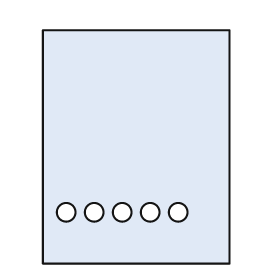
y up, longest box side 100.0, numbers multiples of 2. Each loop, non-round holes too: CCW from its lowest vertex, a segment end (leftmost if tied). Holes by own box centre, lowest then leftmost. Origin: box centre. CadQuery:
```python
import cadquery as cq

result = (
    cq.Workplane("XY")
    .moveTo(-40.0, -50.0)
    .lineTo(40.0, -50.0)
    .lineTo(40.0, 50.0)
    .lineTo(-40.0, 50.0)
    .close()
    .moveTo(-30.0, -28.0)
    .circle(4.0)
    .moveTo(-18.0, -28.0)
    .circle(4.0)
    .moveTo(-6.0, -28.0)
    .circle(4.0)
    .moveTo(6.0, -28.0)
    .circle(4.0)
    .moveTo(18.0, -28.0)
    .circle(4.0)
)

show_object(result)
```